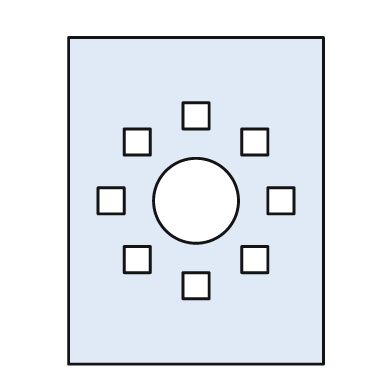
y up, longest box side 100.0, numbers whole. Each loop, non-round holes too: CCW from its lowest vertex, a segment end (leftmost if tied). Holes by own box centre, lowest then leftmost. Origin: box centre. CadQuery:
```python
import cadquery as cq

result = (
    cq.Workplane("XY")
    .moveTo(-39.0, -50.0)
    .lineTo(39.0, -50.0)
    .lineTo(39.0, 50.0)
    .lineTo(-39.0, 50.0)
    .close()
    .moveTo(-4.0, -30.0)
    .lineTo(4.0, -30.0)
    .lineTo(4.0, -22.0)
    .lineTo(-4.0, -22.0)
    .close()
    .moveTo(-22.0, -22.0)
    .lineTo(-14.0, -22.0)
    .lineTo(-14.0, -14.0)
    .lineTo(-22.0, -14.0)
    .close()
    .moveTo(14.0, -22.0)
    .lineTo(22.0, -22.0)
    .lineTo(22.0, -14.0)
    .lineTo(14.0, -14.0)
    .close()
    .moveTo(-30.0, -4.0)
    .lineTo(-22.0, -4.0)
    .lineTo(-22.0, 4.0)
    .lineTo(-30.0, 4.0)
    .close()
    .moveTo(0.0, 0.0)
    .circle(13.0)
    .moveTo(22.0, -4.0)
    .lineTo(30.0, -4.0)
    .lineTo(30.0, 4.0)
    .lineTo(22.0, 4.0)
    .close()
    .moveTo(-22.0, 14.0)
    .lineTo(-14.0, 14.0)
    .lineTo(-14.0, 22.0)
    .lineTo(-22.0, 22.0)
    .close()
    .moveTo(14.0, 14.0)
    .lineTo(22.0, 14.0)
    .lineTo(22.0, 22.0)
    .lineTo(14.0, 22.0)
    .close()
    .moveTo(-4.0, 22.0)
    .lineTo(4.0, 22.0)
    .lineTo(4.0, 30.0)
    .lineTo(-4.0, 30.0)
    .close()
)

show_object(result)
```